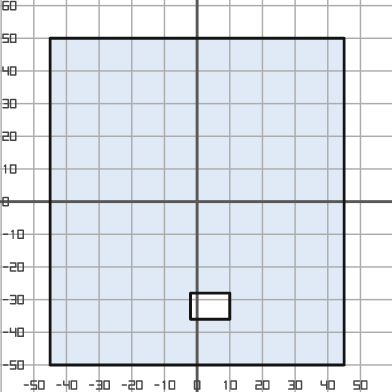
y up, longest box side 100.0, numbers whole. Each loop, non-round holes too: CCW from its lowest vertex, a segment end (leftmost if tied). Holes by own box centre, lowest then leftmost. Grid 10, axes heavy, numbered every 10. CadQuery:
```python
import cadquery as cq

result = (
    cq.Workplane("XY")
    .moveTo(-45.0, -50.0)
    .lineTo(45.0, -50.0)
    .lineTo(45.0, 50.0)
    .lineTo(-45.0, 50.0)
    .close()
    .moveTo(-2.0, -36.0)
    .lineTo(10.0, -36.0)
    .lineTo(10.0, -28.0)
    .lineTo(-2.0, -28.0)
    .close()
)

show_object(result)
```